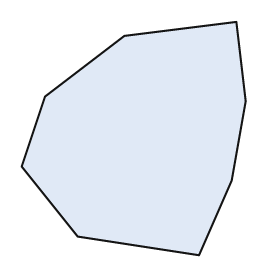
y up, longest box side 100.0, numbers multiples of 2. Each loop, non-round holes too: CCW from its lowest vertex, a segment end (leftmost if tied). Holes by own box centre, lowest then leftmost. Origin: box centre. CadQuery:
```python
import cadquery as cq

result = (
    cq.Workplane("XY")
    .moveTo(28.0, -50.0)
    .lineTo(42.0, -18.0)
    .lineTo(48.0, 16.0)
    .lineTo(44.0, 50.0)
    .lineTo(-4.0, 44.0)
    .lineTo(-38.0, 18.0)
    .lineTo(-48.0, -12.0)
    .lineTo(-24.0, -42.0)
    .close()
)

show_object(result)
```